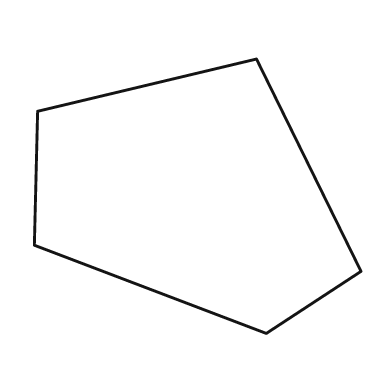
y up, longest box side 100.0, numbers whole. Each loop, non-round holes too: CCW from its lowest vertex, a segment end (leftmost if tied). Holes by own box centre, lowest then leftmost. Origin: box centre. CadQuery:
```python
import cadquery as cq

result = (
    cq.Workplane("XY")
    .moveTo(21.0, -42.0)
    .lineTo(50.0, -23.0)
    .lineTo(18.0, 42.0)
    .lineTo(-49.0, 26.0)
    .lineTo(-50.0, -15.0)
    .close()
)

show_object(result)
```